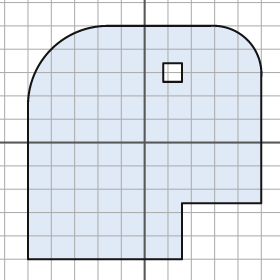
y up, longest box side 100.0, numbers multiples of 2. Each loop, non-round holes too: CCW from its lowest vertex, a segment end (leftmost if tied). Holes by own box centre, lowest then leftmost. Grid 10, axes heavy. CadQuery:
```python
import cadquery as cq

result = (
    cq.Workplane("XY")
    .moveTo(-50.0, -50.0)
    .lineTo(16.0, -50.0)
    .lineTo(16.0, -26.0)
    .lineTo(50.0, -26.0)
    .lineTo(50.0, 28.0)
    .threePointArc((44.0, 44.0), (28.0, 50.0))
    .lineTo(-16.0, 50.0)
    .threePointArc((-40.0, 40.0), (-50.0, 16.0))
    .close()
    .moveTo(8.0, 26.0)
    .lineTo(16.0, 26.0)
    .lineTo(16.0, 34.0)
    .lineTo(8.0, 34.0)
    .close()
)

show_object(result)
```